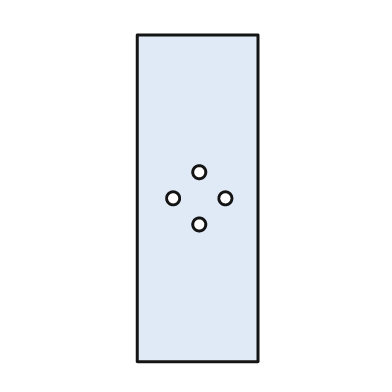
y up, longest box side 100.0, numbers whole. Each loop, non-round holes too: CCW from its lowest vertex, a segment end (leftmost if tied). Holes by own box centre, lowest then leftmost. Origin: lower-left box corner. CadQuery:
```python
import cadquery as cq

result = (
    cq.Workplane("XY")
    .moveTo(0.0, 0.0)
    .lineTo(37.0, 0.0)
    .lineTo(37.0, 100.0)
    .lineTo(0.0, 100.0)
    .close()
    .moveTo(19.0, 42.0)
    .circle(2.0)
    .moveTo(11.0, 50.0)
    .circle(2.0)
    .moveTo(27.0, 50.0)
    .circle(2.0)
    .moveTo(19.0, 58.0)
    .circle(2.0)
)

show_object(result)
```